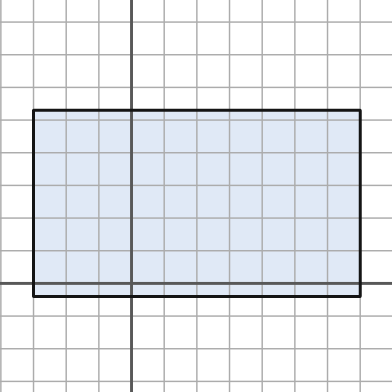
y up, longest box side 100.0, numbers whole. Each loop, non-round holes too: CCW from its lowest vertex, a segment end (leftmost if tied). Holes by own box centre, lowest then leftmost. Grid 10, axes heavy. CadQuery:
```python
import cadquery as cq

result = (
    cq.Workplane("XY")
    .moveTo(-30.0, -4.0)
    .lineTo(70.0, -4.0)
    .lineTo(70.0, 53.0)
    .lineTo(-30.0, 53.0)
    .close()
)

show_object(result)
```